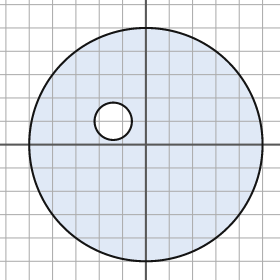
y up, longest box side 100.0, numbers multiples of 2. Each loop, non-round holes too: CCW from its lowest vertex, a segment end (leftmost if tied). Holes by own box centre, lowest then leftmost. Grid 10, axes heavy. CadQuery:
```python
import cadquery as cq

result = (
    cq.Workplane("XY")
    .moveTo(0.0, 0.0)
    .circle(50.0)
    .moveTo(-14.0, 10.0)
    .circle(8.0)
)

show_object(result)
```